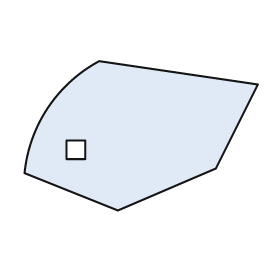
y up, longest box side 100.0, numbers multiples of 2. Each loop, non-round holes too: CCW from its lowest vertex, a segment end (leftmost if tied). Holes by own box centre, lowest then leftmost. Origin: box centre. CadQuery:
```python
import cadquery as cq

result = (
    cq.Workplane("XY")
    .moveTo(-10.0, -32.0)
    .lineTo(32.0, -14.0)
    .lineTo(50.0, 22.0)
    .lineTo(-18.0, 32.0)
    .threePointArc((-40.0, 12.0), (-50.0, -16.0))
    .close()
    .moveTo(-32.0, -10.0)
    .lineTo(-24.0, -10.0)
    .lineTo(-24.0, -2.0)
    .lineTo(-32.0, -2.0)
    .close()
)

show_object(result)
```